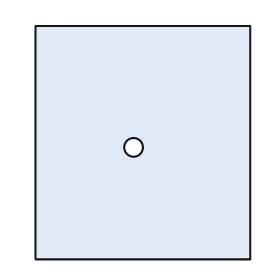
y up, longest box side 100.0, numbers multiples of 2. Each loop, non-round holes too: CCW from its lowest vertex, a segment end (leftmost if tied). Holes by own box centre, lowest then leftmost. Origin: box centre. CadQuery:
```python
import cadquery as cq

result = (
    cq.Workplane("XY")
    .moveTo(-46.0, -50.0)
    .lineTo(46.0, -50.0)
    .lineTo(46.0, 50.0)
    .lineTo(-46.0, 50.0)
    .close()
    .moveTo(-4.0, -2.0)
    .circle(4.0)
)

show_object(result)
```